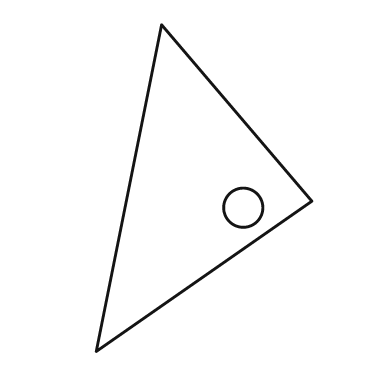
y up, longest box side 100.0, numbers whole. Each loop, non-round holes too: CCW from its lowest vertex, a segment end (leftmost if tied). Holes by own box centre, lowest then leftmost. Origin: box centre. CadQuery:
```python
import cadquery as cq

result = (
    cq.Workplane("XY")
    .moveTo(-33.0, -50.0)
    .lineTo(33.0, -4.0)
    .lineTo(-13.0, 50.0)
    .close()
    .moveTo(12.0, -6.0)
    .circle(6.0)
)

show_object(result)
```